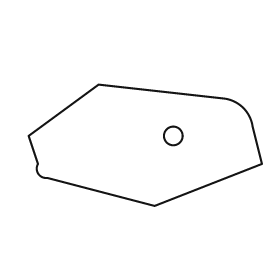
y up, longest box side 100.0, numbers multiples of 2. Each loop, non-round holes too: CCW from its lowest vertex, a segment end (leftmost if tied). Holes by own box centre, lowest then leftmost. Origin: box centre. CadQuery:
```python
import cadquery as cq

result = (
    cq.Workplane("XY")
    .moveTo(4.0, -26.0)
    .lineTo(50.0, -8.0)
    .lineTo(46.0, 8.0)
    .threePointArc((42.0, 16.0), (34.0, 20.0))
    .lineTo(-20.0, 26.0)
    .lineTo(-50.0, 4.0)
    .lineTo(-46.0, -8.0)
    .threePointArc((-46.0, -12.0), (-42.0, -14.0))
    .close()
    .moveTo(12.0, 4.0)
    .circle(4.0)
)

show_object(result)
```